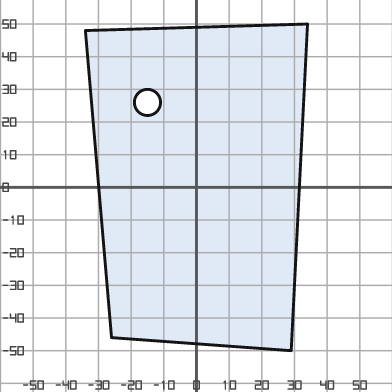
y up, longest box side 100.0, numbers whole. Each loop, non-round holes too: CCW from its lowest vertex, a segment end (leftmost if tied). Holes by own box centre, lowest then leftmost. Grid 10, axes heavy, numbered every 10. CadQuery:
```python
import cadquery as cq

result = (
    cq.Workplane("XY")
    .moveTo(29.0, -50.0)
    .lineTo(34.0, 50.0)
    .lineTo(-34.0, 48.0)
    .lineTo(-26.0, -46.0)
    .close()
    .moveTo(-15.0, 26.0)
    .circle(4.0)
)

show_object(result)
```